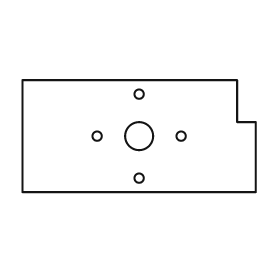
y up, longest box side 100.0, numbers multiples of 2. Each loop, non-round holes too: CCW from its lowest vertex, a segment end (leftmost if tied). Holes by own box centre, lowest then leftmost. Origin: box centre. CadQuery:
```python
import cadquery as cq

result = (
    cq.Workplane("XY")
    .moveTo(-50.0, -24.0)
    .lineTo(50.0, -24.0)
    .lineTo(50.0, 6.0)
    .lineTo(42.0, 6.0)
    .lineTo(42.0, 24.0)
    .lineTo(-50.0, 24.0)
    .close()
    .moveTo(0.0, -18.0)
    .circle(2.0)
    .moveTo(-18.0, 0.0)
    .circle(2.0)
    .moveTo(0.0, 0.0)
    .circle(6.0)
    .moveTo(18.0, 0.0)
    .circle(2.0)
    .moveTo(0.0, 18.0)
    .circle(2.0)
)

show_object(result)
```